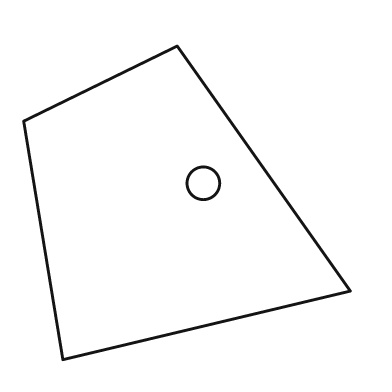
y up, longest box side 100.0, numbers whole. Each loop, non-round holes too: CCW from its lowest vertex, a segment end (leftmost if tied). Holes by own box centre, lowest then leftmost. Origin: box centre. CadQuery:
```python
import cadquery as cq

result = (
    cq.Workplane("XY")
    .moveTo(-38.0, -48.0)
    .lineTo(50.0, -27.0)
    .lineTo(-3.0, 48.0)
    .lineTo(-50.0, 25.0)
    .close()
    .moveTo(5.0, 6.0)
    .circle(5.0)
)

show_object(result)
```